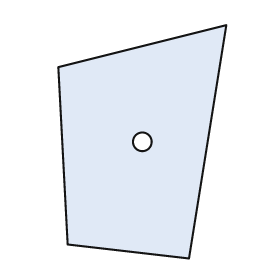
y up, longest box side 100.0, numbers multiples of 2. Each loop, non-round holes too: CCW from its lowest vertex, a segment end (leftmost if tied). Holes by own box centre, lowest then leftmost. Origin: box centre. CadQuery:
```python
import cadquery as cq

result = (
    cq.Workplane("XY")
    .moveTo(20.0, -50.0)
    .lineTo(36.0, 50.0)
    .lineTo(-36.0, 32.0)
    .lineTo(-32.0, -44.0)
    .close()
    .moveTo(0.0, 0.0)
    .circle(4.0)
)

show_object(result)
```